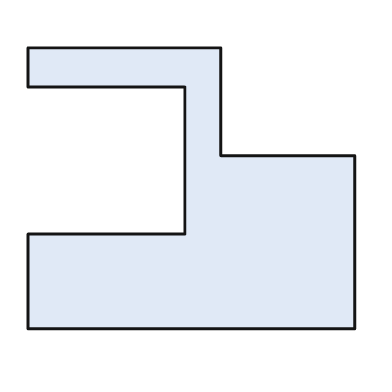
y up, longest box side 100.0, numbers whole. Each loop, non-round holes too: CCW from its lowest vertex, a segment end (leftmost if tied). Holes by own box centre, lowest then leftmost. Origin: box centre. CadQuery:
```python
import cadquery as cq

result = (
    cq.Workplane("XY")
    .moveTo(-50.0, -43.0)
    .lineTo(50.0, -43.0)
    .lineTo(50.0, 10.0)
    .lineTo(9.0, 10.0)
    .lineTo(9.0, 43.0)
    .lineTo(-50.0, 43.0)
    .lineTo(-50.0, 31.0)
    .lineTo(-2.0, 31.0)
    .lineTo(-2.0, -14.0)
    .lineTo(-50.0, -14.0)
    .close()
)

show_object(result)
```